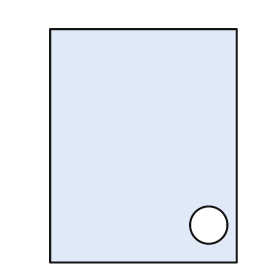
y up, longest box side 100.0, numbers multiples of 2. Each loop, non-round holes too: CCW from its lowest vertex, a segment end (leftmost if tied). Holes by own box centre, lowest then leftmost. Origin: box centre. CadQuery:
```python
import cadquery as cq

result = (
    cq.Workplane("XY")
    .moveTo(-40.0, -50.0)
    .lineTo(40.0, -50.0)
    .lineTo(40.0, 50.0)
    .lineTo(-40.0, 50.0)
    .close()
    .moveTo(28.0, -34.0)
    .circle(8.0)
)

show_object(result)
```